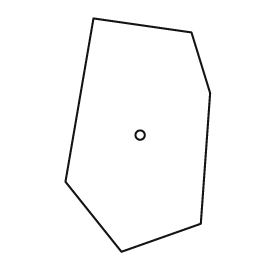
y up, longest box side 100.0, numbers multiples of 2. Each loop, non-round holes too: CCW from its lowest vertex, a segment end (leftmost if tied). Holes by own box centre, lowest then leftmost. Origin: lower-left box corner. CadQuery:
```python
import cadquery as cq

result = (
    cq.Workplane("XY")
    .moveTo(24.0, 0.0)
    .lineTo(58.0, 12.0)
    .lineTo(62.0, 68.0)
    .lineTo(54.0, 94.0)
    .lineTo(12.0, 100.0)
    .lineTo(0.0, 30.0)
    .close()
    .moveTo(32.0, 50.0)
    .circle(2.0)
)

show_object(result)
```